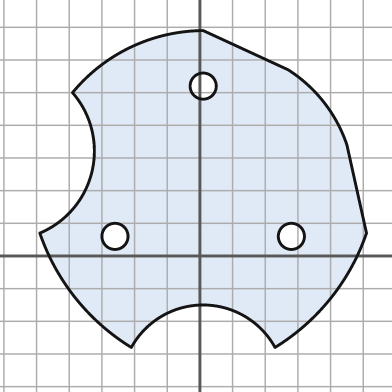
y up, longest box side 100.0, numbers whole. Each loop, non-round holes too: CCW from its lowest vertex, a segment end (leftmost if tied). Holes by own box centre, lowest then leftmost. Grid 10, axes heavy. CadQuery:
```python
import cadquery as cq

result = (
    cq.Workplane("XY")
    .moveTo(-21.0, -28.0)
    .threePointArc((1.0, -15.0), (23.0, -28.0))
    .threePointArc((40.0, -13.0), (51.0, 7.0))
    .lineTo(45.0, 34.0)
    .threePointArc((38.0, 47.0), (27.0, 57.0))
    .lineTo(1.0, 69.0)
    .threePointArc((-21.0, 64.0), (-39.0, 50.0))
    .threePointArc((-33.0, 26.0), (-49.0, 7.0))
    .threePointArc((-38.0, -13.0), (-21.0, -28.0))
    .close()
    .moveTo(-26.0, 6.0)
    .circle(4.0)
    .moveTo(28.0, 6.0)
    .circle(4.0)
    .moveTo(1.0, 52.0)
    .circle(4.0)
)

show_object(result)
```